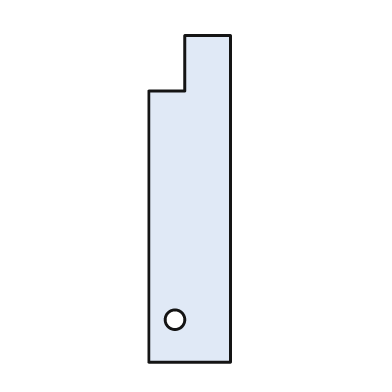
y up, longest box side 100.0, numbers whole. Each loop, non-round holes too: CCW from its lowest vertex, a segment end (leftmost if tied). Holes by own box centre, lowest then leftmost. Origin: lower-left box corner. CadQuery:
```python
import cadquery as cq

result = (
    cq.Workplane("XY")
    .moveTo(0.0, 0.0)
    .lineTo(25.0, 0.0)
    .lineTo(25.0, 100.0)
    .lineTo(11.0, 100.0)
    .lineTo(11.0, 83.0)
    .lineTo(0.0, 83.0)
    .close()
    .moveTo(8.0, 13.0)
    .circle(3.0)
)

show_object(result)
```